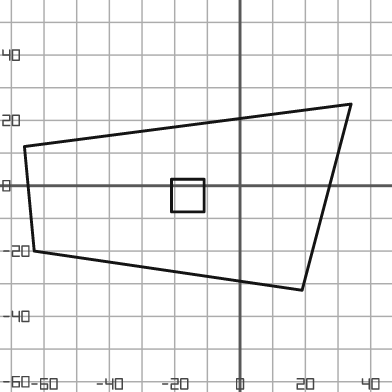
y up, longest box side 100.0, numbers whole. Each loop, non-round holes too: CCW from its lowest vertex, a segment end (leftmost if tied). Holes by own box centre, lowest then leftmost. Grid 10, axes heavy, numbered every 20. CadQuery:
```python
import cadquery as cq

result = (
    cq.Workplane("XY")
    .moveTo(19.0, -32.0)
    .lineTo(34.0, 25.0)
    .lineTo(-66.0, 12.0)
    .lineTo(-63.0, -20.0)
    .close()
    .moveTo(-21.0, -8.0)
    .lineTo(-11.0, -8.0)
    .lineTo(-11.0, 2.0)
    .lineTo(-21.0, 2.0)
    .close()
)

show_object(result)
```